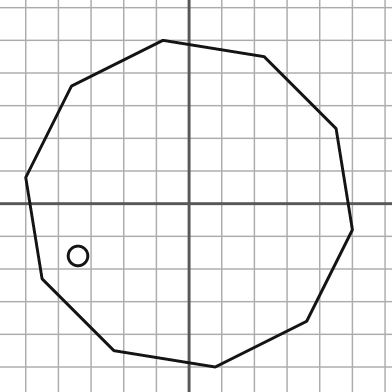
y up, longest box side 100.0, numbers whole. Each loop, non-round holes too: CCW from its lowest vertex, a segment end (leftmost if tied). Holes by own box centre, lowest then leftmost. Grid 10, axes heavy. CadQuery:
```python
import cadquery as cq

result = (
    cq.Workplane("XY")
    .moveTo(8.0, -50.0)
    .lineTo(36.0, -36.0)
    .lineTo(50.0, -8.0)
    .lineTo(45.0, 23.0)
    .lineTo(23.0, 45.0)
    .lineTo(-8.0, 50.0)
    .lineTo(-36.0, 36.0)
    .lineTo(-50.0, 8.0)
    .lineTo(-45.0, -23.0)
    .lineTo(-23.0, -45.0)
    .close()
    .moveTo(-34.0, -16.0)
    .circle(3.0)
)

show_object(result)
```